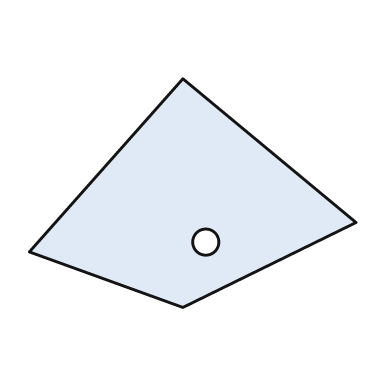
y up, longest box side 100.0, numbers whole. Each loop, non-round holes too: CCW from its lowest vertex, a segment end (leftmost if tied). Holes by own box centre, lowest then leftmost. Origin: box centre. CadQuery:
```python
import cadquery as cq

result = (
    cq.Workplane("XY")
    .moveTo(-3.0, -35.0)
    .lineTo(50.0, -9.0)
    .lineTo(-3.0, 35.0)
    .lineTo(-50.0, -18.0)
    .close()
    .moveTo(4.0, -15.0)
    .circle(4.0)
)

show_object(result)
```